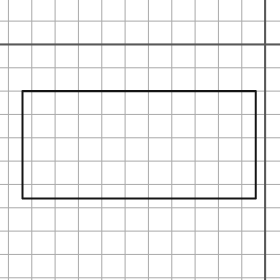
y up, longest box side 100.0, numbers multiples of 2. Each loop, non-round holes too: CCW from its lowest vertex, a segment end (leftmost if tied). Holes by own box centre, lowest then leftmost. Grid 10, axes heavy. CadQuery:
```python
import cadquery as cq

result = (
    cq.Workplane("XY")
    .moveTo(-104.0, -66.0)
    .lineTo(-4.0, -66.0)
    .lineTo(-4.0, -20.0)
    .lineTo(-104.0, -20.0)
    .close()
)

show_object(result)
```